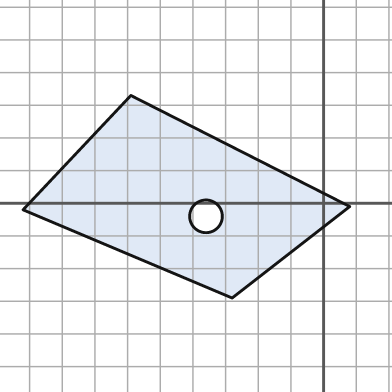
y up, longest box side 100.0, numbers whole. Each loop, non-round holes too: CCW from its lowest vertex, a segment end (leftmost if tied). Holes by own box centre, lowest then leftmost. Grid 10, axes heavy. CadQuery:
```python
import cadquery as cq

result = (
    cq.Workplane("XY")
    .moveTo(-28.0, -29.0)
    .lineTo(8.0, -1.0)
    .lineTo(-59.0, 33.0)
    .lineTo(-92.0, -2.0)
    .close()
    .moveTo(-36.0, -4.0)
    .circle(5.0)
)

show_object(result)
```